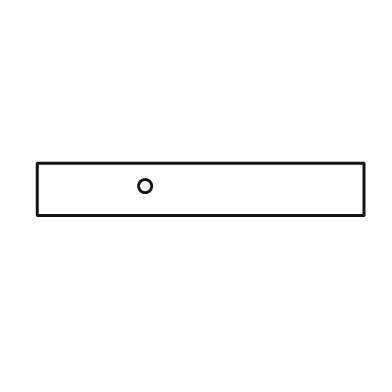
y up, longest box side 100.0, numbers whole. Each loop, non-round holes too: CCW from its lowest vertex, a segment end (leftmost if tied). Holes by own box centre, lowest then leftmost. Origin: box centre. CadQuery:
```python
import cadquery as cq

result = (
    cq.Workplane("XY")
    .moveTo(-50.0, -8.0)
    .lineTo(50.0, -8.0)
    .lineTo(50.0, 8.0)
    .lineTo(-50.0, 8.0)
    .close()
    .moveTo(-17.0, 1.0)
    .circle(2.0)
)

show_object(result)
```